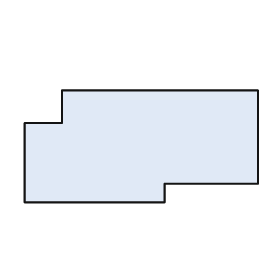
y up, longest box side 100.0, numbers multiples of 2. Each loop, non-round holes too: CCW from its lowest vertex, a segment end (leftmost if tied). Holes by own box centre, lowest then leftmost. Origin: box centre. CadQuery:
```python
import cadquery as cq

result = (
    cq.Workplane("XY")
    .moveTo(-50.0, -24.0)
    .lineTo(10.0, -24.0)
    .lineTo(10.0, -16.0)
    .lineTo(50.0, -16.0)
    .lineTo(50.0, 24.0)
    .lineTo(-34.0, 24.0)
    .lineTo(-34.0, 10.0)
    .lineTo(-50.0, 10.0)
    .close()
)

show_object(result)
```